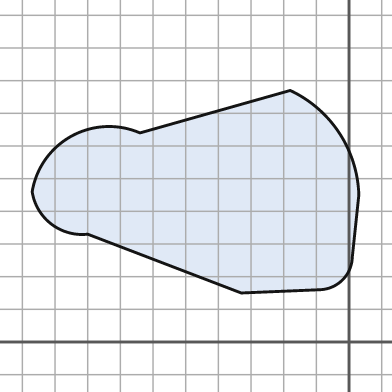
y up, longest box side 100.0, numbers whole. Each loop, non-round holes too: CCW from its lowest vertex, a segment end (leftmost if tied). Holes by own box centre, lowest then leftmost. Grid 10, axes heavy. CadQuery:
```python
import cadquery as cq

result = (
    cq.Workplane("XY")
    .moveTo(-33.0, 15.0)
    .lineTo(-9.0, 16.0)
    .threePointArc((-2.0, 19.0), (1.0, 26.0))
    .lineTo(3.0, 45.0)
    .threePointArc((-3.0, 64.0), (-18.0, 77.0))
    .lineTo(-64.0, 64.0)
    .threePointArc((-85.0, 63.0), (-97.0, 46.0))
    .threePointArc((-91.0, 36.0), (-80.0, 33.0))
    .close()
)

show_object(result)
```